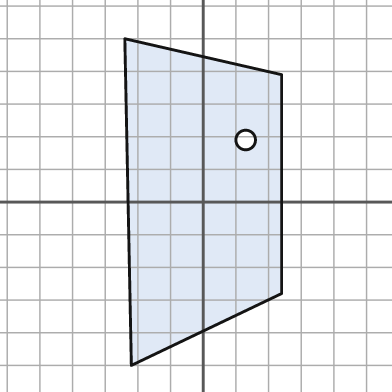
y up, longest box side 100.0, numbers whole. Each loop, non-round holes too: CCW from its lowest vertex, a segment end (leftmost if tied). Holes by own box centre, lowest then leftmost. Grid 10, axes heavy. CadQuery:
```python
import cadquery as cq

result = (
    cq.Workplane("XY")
    .moveTo(-22.0, -50.0)
    .lineTo(24.0, -28.0)
    .lineTo(24.0, 39.0)
    .lineTo(-24.0, 50.0)
    .close()
    .moveTo(13.0, 19.0)
    .circle(3.0)
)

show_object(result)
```